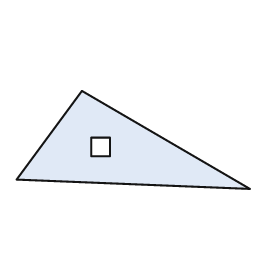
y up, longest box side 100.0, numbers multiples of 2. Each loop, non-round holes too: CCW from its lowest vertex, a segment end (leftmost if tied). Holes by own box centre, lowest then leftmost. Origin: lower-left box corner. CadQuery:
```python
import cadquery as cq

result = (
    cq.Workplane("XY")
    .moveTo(100.0, 0.0)
    .lineTo(28.0, 42.0)
    .lineTo(0.0, 4.0)
    .close()
    .moveTo(32.0, 14.0)
    .lineTo(40.0, 14.0)
    .lineTo(40.0, 22.0)
    .lineTo(32.0, 22.0)
    .close()
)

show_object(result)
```